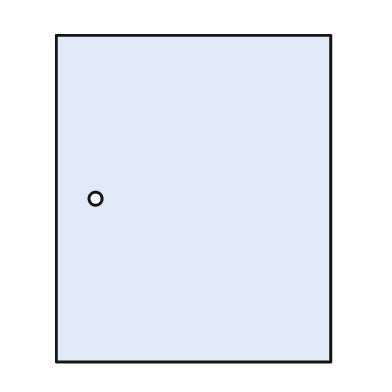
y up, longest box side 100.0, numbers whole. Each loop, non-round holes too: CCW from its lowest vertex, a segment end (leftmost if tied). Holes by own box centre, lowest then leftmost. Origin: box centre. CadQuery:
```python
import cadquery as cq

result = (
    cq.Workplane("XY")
    .moveTo(-42.0, -50.0)
    .lineTo(42.0, -50.0)
    .lineTo(42.0, 50.0)
    .lineTo(-42.0, 50.0)
    .close()
    .moveTo(-30.0, 0.0)
    .circle(2.0)
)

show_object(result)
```